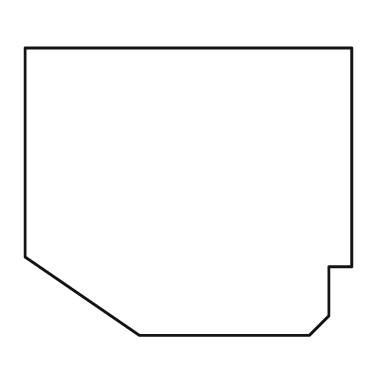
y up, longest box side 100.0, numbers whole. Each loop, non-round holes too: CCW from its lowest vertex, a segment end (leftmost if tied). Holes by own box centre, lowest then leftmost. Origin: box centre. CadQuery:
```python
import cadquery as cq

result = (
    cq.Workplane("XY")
    .moveTo(-15.0, -44.0)
    .lineTo(37.0, -44.0)
    .lineTo(43.0, -38.0)
    .lineTo(43.0, -23.0)
    .lineTo(50.0, -23.0)
    .lineTo(50.0, 44.0)
    .lineTo(-50.0, 44.0)
    .lineTo(-50.0, -20.0)
    .close()
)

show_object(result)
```